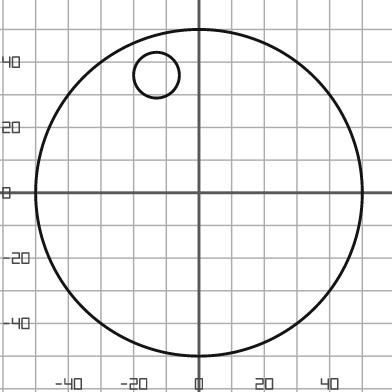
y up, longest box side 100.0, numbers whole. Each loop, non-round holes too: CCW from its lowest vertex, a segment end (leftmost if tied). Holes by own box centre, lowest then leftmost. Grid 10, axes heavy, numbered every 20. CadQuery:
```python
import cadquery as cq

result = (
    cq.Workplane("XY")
    .moveTo(0.0, 0.0)
    .circle(50.0)
    .moveTo(-13.0, 36.0)
    .circle(7.0)
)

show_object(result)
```